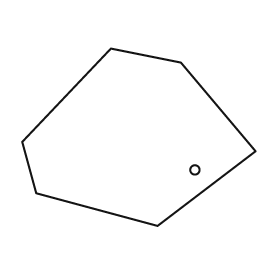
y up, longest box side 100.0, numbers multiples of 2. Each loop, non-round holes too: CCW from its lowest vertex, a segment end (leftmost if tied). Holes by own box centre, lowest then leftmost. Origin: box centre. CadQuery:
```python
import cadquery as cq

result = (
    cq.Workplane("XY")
    .moveTo(8.0, -38.0)
    .lineTo(50.0, -6.0)
    .lineTo(18.0, 32.0)
    .lineTo(-12.0, 38.0)
    .lineTo(-50.0, -2.0)
    .lineTo(-44.0, -24.0)
    .close()
    .moveTo(24.0, -14.0)
    .circle(2.0)
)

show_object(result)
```